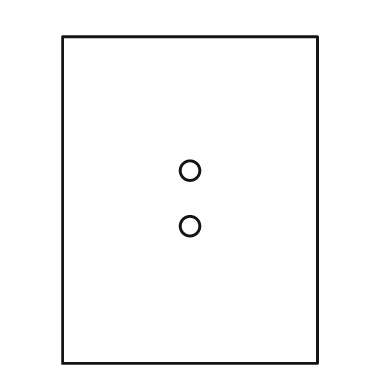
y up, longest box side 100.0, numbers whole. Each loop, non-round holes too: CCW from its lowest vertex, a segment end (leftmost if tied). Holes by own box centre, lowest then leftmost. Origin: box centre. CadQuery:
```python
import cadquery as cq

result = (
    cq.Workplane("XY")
    .moveTo(-39.0, -50.0)
    .lineTo(39.0, -50.0)
    .lineTo(39.0, 50.0)
    .lineTo(-39.0, 50.0)
    .close()
    .moveTo(0.0, -8.0)
    .circle(3.0)
    .moveTo(0.0, 9.0)
    .circle(3.0)
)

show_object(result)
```